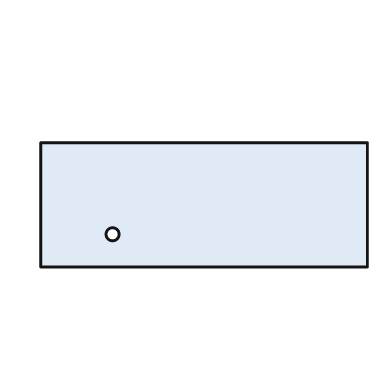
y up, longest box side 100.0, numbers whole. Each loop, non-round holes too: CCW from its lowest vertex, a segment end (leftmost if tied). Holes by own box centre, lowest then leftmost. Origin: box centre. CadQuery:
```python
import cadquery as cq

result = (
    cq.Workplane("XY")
    .moveTo(-50.0, -19.0)
    .lineTo(50.0, -19.0)
    .lineTo(50.0, 19.0)
    .lineTo(-50.0, 19.0)
    .close()
    .moveTo(-28.0, -9.0)
    .circle(2.0)
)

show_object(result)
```